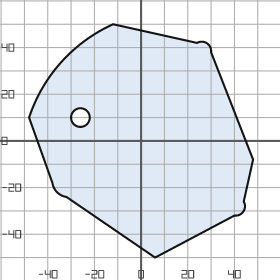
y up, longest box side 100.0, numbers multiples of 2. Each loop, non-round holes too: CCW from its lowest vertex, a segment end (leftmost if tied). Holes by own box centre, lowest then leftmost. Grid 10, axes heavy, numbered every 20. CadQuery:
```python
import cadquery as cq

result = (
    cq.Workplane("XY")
    .moveTo(6.0, -50.0)
    .lineTo(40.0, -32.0)
    .threePointArc((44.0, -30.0), (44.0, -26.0))
    .lineTo(48.0, -8.0)
    .lineTo(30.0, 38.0)
    .threePointArc((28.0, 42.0), (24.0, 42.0))
    .lineTo(-12.0, 50.0)
    .threePointArc((-34.0, 34.0), (-48.0, 10.0))
    .lineTo(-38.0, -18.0)
    .threePointArc((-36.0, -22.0), (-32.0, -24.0))
    .close()
    .moveTo(-26.0, 10.0)
    .circle(4.0)
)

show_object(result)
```